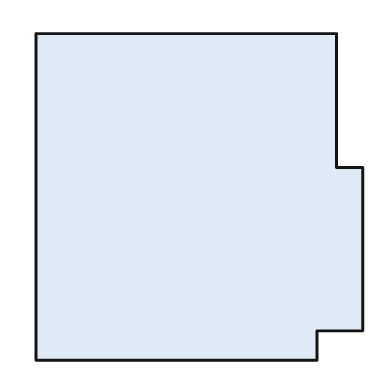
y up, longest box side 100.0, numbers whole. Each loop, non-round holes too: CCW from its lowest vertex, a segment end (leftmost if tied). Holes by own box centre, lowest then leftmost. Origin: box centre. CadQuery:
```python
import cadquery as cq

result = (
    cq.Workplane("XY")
    .moveTo(-50.0, -50.0)
    .lineTo(36.0, -50.0)
    .lineTo(36.0, -41.0)
    .lineTo(50.0, -41.0)
    .lineTo(50.0, 9.0)
    .lineTo(42.0, 9.0)
    .lineTo(42.0, 50.0)
    .lineTo(-50.0, 50.0)
    .close()
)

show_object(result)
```